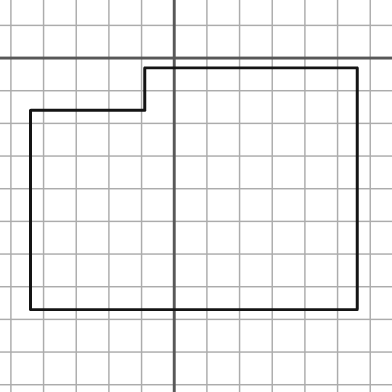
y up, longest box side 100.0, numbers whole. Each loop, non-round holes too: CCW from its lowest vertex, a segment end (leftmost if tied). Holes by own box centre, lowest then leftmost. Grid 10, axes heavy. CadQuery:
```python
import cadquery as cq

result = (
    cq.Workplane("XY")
    .moveTo(-44.0, -77.0)
    .lineTo(56.0, -77.0)
    .lineTo(56.0, -3.0)
    .lineTo(-9.0, -3.0)
    .lineTo(-9.0, -16.0)
    .lineTo(-44.0, -16.0)
    .close()
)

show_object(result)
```